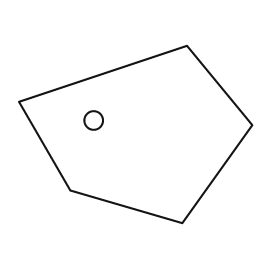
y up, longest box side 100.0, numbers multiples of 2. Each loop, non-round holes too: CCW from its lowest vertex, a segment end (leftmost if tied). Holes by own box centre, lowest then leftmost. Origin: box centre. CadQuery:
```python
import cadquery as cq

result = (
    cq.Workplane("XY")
    .moveTo(20.0, -38.0)
    .lineTo(50.0, 4.0)
    .lineTo(22.0, 38.0)
    .lineTo(-50.0, 14.0)
    .lineTo(-28.0, -24.0)
    .close()
    .moveTo(-18.0, 6.0)
    .circle(4.0)
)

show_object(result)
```